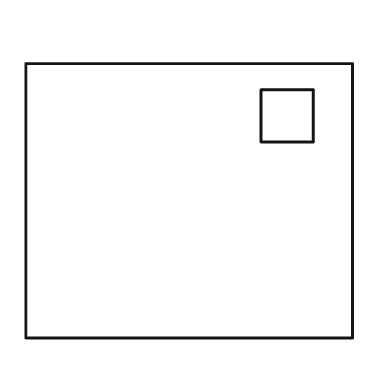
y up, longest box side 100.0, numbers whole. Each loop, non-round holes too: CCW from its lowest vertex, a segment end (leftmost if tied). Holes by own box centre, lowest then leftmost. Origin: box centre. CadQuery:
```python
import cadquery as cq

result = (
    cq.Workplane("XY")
    .moveTo(-50.0, -42.0)
    .lineTo(50.0, -42.0)
    .lineTo(50.0, 42.0)
    .lineTo(-50.0, 42.0)
    .close()
    .moveTo(22.0, 18.0)
    .lineTo(38.0, 18.0)
    .lineTo(38.0, 34.0)
    .lineTo(22.0, 34.0)
    .close()
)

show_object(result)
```